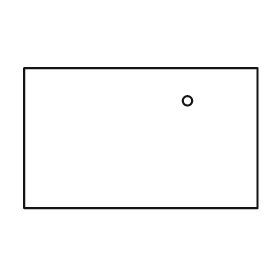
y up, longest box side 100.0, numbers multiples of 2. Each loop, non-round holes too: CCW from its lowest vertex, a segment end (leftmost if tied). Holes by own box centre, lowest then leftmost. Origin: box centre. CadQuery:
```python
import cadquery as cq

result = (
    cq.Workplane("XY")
    .moveTo(-50.0, -30.0)
    .lineTo(50.0, -30.0)
    .lineTo(50.0, 30.0)
    .lineTo(-50.0, 30.0)
    .close()
    .moveTo(20.0, 16.0)
    .circle(2.0)
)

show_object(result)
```